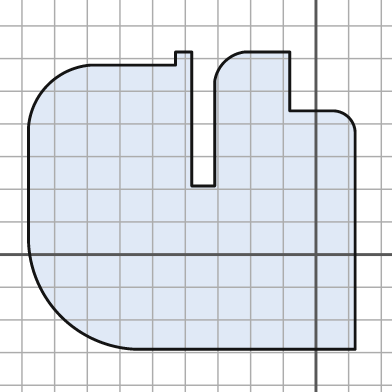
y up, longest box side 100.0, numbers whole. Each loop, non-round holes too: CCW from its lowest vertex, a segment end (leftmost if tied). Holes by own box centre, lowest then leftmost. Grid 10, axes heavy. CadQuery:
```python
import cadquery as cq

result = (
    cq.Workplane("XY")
    .moveTo(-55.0, -29.0)
    .lineTo(12.0, -29.0)
    .lineTo(12.0, 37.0)
    .threePointArc((10.0, 42.0), (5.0, 44.0))
    .lineTo(-8.0, 44.0)
    .lineTo(-8.0, 62.0)
    .lineTo(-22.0, 62.0)
    .threePointArc((-28.0, 59.0), (-31.0, 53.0))
    .lineTo(-31.0, 21.0)
    .lineTo(-38.0, 21.0)
    .lineTo(-38.0, 62.0)
    .lineTo(-43.0, 62.0)
    .lineTo(-43.0, 58.0)
    .lineTo(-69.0, 58.0)
    .threePointArc((-82.0, 52.0), (-88.0, 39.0))
    .lineTo(-88.0, 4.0)
    .threePointArc((-78.0, -19.0), (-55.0, -29.0))
    .close()
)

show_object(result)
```